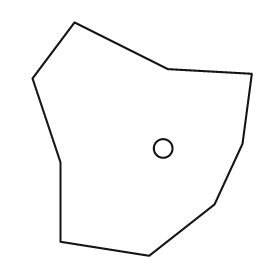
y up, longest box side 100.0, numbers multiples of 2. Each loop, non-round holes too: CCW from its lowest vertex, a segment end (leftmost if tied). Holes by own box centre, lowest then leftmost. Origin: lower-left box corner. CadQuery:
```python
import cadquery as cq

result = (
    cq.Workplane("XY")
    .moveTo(50.0, 0.0)
    .lineTo(78.0, 22.0)
    .lineTo(90.0, 48.0)
    .lineTo(94.0, 78.0)
    .lineTo(58.0, 80.0)
    .lineTo(18.0, 100.0)
    .lineTo(0.0, 76.0)
    .lineTo(12.0, 40.0)
    .lineTo(12.0, 6.0)
    .close()
    .moveTo(56.0, 46.0)
    .circle(4.0)
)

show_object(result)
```